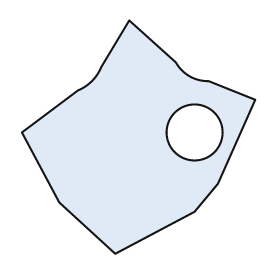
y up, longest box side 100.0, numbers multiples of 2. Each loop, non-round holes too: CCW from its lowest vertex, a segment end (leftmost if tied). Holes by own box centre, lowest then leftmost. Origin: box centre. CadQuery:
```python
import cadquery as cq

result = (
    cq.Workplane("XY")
    .moveTo(-10.0, -50.0)
    .lineTo(24.0, -32.0)
    .lineTo(34.0, -20.0)
    .lineTo(50.0, 16.0)
    .lineTo(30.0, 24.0)
    .threePointArc((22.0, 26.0), (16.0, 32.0))
    .lineTo(-4.0, 50.0)
    .lineTo(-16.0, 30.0)
    .threePointArc((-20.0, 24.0), (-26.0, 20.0))
    .lineTo(-50.0, 2.0)
    .lineTo(-34.0, -28.0)
    .close()
    .moveTo(24.0, 2.0)
    .circle(12.0)
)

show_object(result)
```